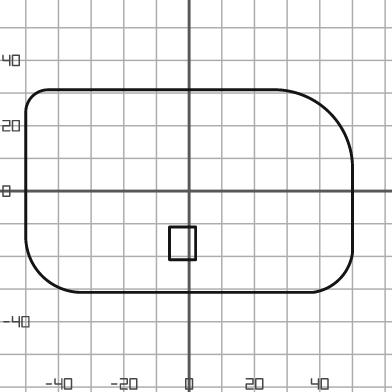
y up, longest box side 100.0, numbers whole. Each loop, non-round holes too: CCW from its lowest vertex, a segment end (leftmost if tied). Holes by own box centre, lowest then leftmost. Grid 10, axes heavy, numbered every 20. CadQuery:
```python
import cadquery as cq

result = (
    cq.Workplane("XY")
    .moveTo(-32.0, -31.0)
    .lineTo(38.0, -31.0)
    .threePointArc((46.0, -27.0), (50.0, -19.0))
    .lineTo(50.0, 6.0)
    .threePointArc((43.0, 24.0), (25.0, 31.0))
    .lineTo(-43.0, 31.0)
    .threePointArc((-48.0, 29.0), (-50.0, 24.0))
    .lineTo(-50.0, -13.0)
    .threePointArc((-45.0, -26.0), (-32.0, -31.0))
    .close()
    .moveTo(-6.0, -21.0)
    .lineTo(2.0, -21.0)
    .lineTo(2.0, -11.0)
    .lineTo(-6.0, -11.0)
    .close()
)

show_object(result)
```